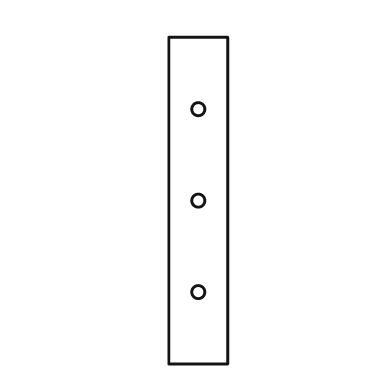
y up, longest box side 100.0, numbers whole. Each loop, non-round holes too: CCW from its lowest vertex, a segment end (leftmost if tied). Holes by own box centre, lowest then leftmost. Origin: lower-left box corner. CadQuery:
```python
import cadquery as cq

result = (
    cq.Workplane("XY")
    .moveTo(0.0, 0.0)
    .lineTo(18.0, 0.0)
    .lineTo(18.0, 100.0)
    .lineTo(0.0, 100.0)
    .close()
    .moveTo(9.0, 22.0)
    .circle(2.0)
    .moveTo(9.0, 50.0)
    .circle(2.0)
    .moveTo(9.0, 78.0)
    .circle(2.0)
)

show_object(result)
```